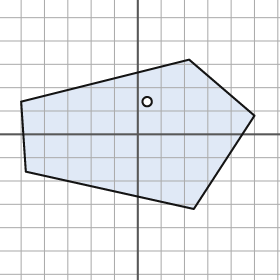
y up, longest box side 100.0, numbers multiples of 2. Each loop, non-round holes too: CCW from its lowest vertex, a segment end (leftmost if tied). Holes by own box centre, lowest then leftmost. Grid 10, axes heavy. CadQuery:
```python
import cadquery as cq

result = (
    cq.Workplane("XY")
    .moveTo(24.0, -32.0)
    .lineTo(50.0, 8.0)
    .lineTo(22.0, 32.0)
    .lineTo(-50.0, 14.0)
    .lineTo(-48.0, -16.0)
    .close()
    .moveTo(4.0, 14.0)
    .circle(2.0)
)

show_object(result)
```